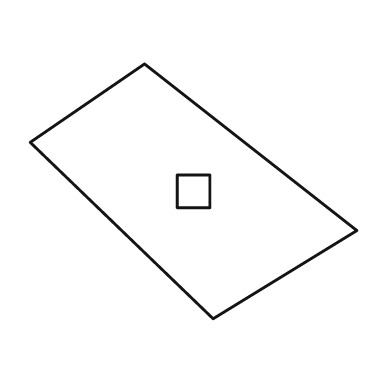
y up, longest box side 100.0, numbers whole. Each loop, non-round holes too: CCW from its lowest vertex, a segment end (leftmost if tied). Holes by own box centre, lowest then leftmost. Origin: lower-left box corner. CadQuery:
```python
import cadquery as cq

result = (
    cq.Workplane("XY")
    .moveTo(56.0, 0.0)
    .lineTo(100.0, 27.0)
    .lineTo(35.0, 78.0)
    .lineTo(0.0, 54.0)
    .close()
    .moveTo(45.0, 34.0)
    .lineTo(55.0, 34.0)
    .lineTo(55.0, 44.0)
    .lineTo(45.0, 44.0)
    .close()
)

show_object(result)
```